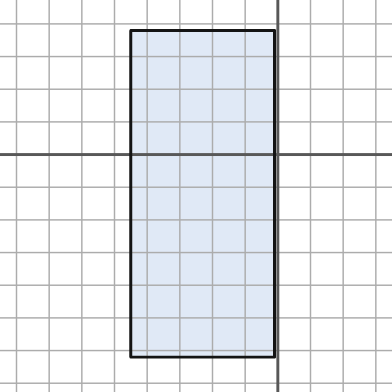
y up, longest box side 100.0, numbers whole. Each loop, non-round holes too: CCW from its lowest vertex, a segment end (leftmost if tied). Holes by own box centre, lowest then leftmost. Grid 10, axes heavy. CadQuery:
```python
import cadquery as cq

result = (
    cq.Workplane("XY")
    .moveTo(-45.0, -62.0)
    .lineTo(-1.0, -62.0)
    .lineTo(-1.0, 38.0)
    .lineTo(-45.0, 38.0)
    .close()
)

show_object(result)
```